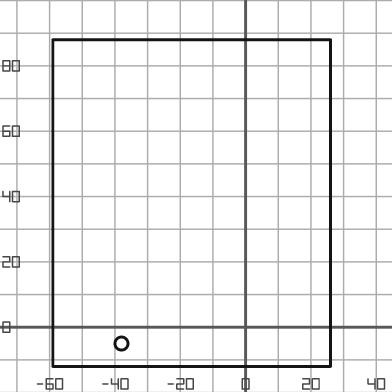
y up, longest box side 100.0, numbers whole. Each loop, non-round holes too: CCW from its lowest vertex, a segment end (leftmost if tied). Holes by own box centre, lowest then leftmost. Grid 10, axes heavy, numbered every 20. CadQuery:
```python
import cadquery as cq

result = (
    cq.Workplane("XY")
    .moveTo(-59.0, -12.0)
    .lineTo(26.0, -12.0)
    .lineTo(26.0, 88.0)
    .lineTo(-59.0, 88.0)
    .close()
    .moveTo(-38.0, -5.0)
    .circle(2.0)
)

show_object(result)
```